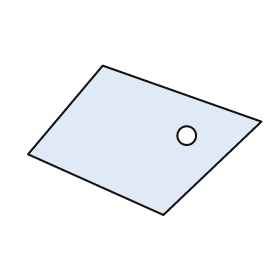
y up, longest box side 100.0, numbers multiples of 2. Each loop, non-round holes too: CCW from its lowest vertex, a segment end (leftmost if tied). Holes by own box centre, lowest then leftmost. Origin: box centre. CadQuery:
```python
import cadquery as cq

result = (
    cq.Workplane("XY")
    .moveTo(8.0, -32.0)
    .lineTo(50.0, 8.0)
    .lineTo(-18.0, 32.0)
    .lineTo(-50.0, -6.0)
    .close()
    .moveTo(18.0, 2.0)
    .circle(4.0)
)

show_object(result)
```